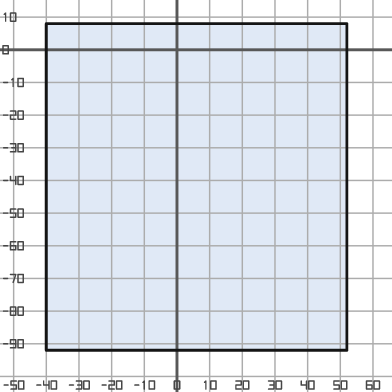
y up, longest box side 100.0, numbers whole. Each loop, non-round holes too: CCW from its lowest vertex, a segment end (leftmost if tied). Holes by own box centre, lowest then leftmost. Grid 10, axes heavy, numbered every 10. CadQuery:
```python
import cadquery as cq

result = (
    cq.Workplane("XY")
    .moveTo(-40.0, -92.0)
    .lineTo(52.0, -92.0)
    .lineTo(52.0, 8.0)
    .lineTo(-40.0, 8.0)
    .close()
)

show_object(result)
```